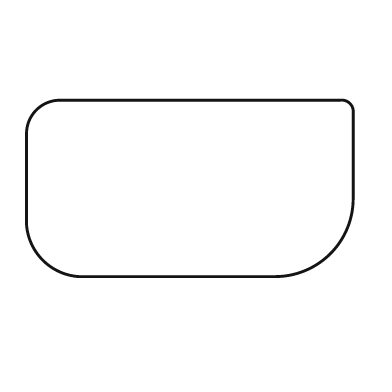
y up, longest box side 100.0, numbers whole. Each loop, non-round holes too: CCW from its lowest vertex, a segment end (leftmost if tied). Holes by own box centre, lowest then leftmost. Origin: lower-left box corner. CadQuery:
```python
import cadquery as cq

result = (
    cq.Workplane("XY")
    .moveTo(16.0, 0.0)
    .lineTo(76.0, 0.0)
    .threePointArc((93.0, 7.0), (100.0, 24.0))
    .lineTo(100.0, 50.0)
    .threePointArc((99.0, 53.0), (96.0, 54.0))
    .lineTo(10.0, 54.0)
    .threePointArc((3.0, 51.0), (0.0, 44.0))
    .lineTo(0.0, 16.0)
    .threePointArc((5.0, 5.0), (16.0, 0.0))
    .close()
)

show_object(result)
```